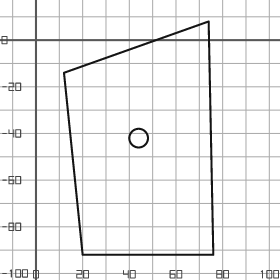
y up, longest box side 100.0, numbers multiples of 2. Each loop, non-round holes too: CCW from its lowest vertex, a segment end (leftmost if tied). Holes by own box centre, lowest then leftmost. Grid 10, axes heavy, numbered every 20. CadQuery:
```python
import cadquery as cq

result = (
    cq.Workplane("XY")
    .moveTo(20.0, -92.0)
    .lineTo(76.0, -92.0)
    .lineTo(74.0, 8.0)
    .lineTo(12.0, -14.0)
    .close()
    .moveTo(44.0, -42.0)
    .circle(4.0)
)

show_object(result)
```